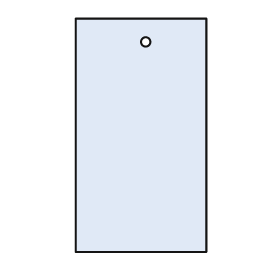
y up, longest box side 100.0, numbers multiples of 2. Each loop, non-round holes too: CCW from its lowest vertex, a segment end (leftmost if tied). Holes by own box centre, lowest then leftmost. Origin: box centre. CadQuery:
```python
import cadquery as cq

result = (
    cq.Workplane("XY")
    .moveTo(-28.0, -50.0)
    .lineTo(28.0, -50.0)
    .lineTo(28.0, 50.0)
    .lineTo(-28.0, 50.0)
    .close()
    .moveTo(2.0, 40.0)
    .circle(2.0)
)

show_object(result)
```